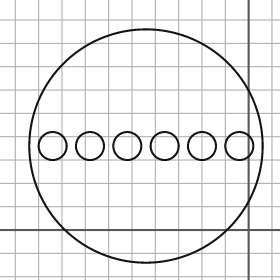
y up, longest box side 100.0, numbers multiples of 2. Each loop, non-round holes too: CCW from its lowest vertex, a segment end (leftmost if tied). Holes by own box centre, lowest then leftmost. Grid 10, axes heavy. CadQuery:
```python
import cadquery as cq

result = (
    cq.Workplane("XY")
    .moveTo(-44.0, 36.0)
    .circle(50.0)
    .moveTo(-84.0, 36.0)
    .circle(6.0)
    .moveTo(-68.0, 36.0)
    .circle(6.0)
    .moveTo(-52.0, 36.0)
    .circle(6.0)
    .moveTo(-36.0, 36.0)
    .circle(6.0)
    .moveTo(-20.0, 36.0)
    .circle(6.0)
    .moveTo(-4.0, 36.0)
    .circle(6.0)
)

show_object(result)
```